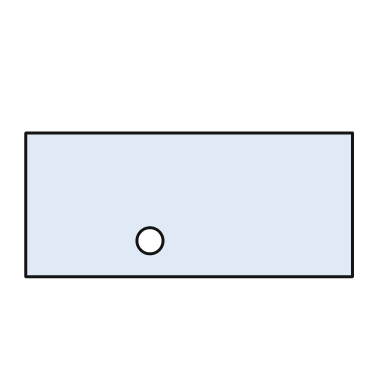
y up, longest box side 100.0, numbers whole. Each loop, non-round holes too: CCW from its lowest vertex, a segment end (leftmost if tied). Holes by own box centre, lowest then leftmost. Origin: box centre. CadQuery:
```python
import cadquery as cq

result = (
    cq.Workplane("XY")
    .moveTo(-50.0, -22.0)
    .lineTo(50.0, -22.0)
    .lineTo(50.0, 22.0)
    .lineTo(-50.0, 22.0)
    .close()
    .moveTo(-12.0, -11.0)
    .circle(4.0)
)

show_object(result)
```